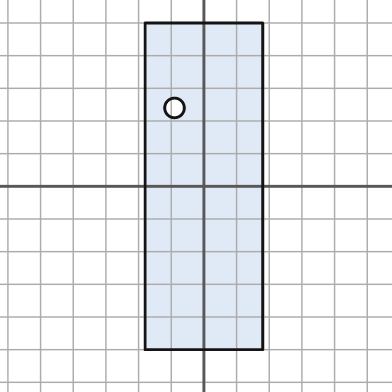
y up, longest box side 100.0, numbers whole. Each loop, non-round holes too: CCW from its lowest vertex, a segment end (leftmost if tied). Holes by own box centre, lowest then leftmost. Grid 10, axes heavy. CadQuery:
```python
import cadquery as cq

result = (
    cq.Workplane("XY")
    .moveTo(-18.0, -50.0)
    .lineTo(18.0, -50.0)
    .lineTo(18.0, 50.0)
    .lineTo(-18.0, 50.0)
    .close()
    .moveTo(-9.0, 24.0)
    .circle(3.0)
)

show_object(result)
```